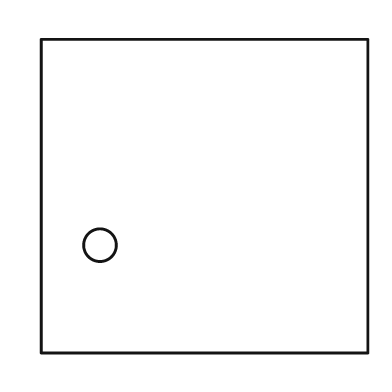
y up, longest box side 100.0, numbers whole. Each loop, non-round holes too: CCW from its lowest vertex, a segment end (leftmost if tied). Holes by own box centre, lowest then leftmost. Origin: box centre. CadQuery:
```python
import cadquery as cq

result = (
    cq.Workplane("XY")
    .moveTo(-50.0, -48.0)
    .lineTo(50.0, -48.0)
    .lineTo(50.0, 48.0)
    .lineTo(-50.0, 48.0)
    .close()
    .moveTo(-32.0, -15.0)
    .circle(5.0)
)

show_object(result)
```